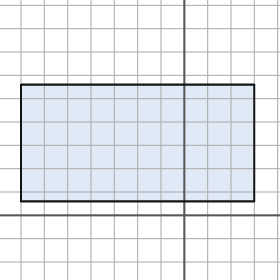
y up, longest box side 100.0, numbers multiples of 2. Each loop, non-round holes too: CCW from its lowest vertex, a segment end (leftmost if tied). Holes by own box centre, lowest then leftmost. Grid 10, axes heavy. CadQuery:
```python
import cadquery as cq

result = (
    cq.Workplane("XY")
    .moveTo(-70.0, 6.0)
    .lineTo(30.0, 6.0)
    .lineTo(30.0, 56.0)
    .lineTo(-70.0, 56.0)
    .close()
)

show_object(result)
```